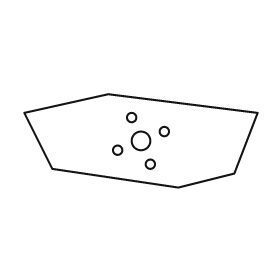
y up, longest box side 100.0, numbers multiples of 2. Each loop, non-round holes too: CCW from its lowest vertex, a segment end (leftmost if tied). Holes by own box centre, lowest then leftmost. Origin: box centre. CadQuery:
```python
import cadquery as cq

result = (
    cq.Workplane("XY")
    .moveTo(16.0, -20.0)
    .lineTo(40.0, -14.0)
    .lineTo(50.0, 12.0)
    .lineTo(-14.0, 20.0)
    .lineTo(-50.0, 12.0)
    .lineTo(-38.0, -12.0)
    .close()
    .moveTo(4.0, -10.0)
    .circle(2.0)
    .moveTo(-10.0, -4.0)
    .circle(2.0)
    .moveTo(0.0, 0.0)
    .circle(4.0)
    .moveTo(10.0, 4.0)
    .circle(2.0)
    .moveTo(-4.0, 10.0)
    .circle(2.0)
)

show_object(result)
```